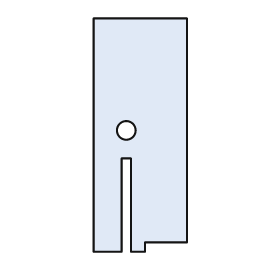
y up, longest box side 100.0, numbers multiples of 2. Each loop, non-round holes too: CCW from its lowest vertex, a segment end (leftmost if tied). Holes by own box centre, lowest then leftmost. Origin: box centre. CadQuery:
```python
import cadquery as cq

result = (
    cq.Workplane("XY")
    .moveTo(-20.0, -50.0)
    .lineTo(-8.0, -50.0)
    .lineTo(-8.0, -10.0)
    .lineTo(-4.0, -10.0)
    .lineTo(-4.0, -50.0)
    .lineTo(2.0, -50.0)
    .lineTo(2.0, -46.0)
    .lineTo(20.0, -46.0)
    .lineTo(20.0, 50.0)
    .lineTo(-20.0, 50.0)
    .close()
    .moveTo(-6.0, 2.0)
    .circle(4.0)
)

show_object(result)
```